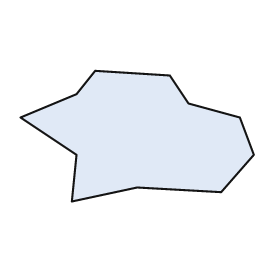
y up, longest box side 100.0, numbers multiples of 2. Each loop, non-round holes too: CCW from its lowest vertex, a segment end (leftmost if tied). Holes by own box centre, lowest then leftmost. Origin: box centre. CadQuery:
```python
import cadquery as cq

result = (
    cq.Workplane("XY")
    .moveTo(-28.0, -28.0)
    .lineTo(0.0, -22.0)
    .lineTo(36.0, -24.0)
    .lineTo(50.0, -8.0)
    .lineTo(44.0, 8.0)
    .lineTo(22.0, 14.0)
    .lineTo(14.0, 26.0)
    .lineTo(-18.0, 28.0)
    .lineTo(-26.0, 18.0)
    .lineTo(-50.0, 8.0)
    .lineTo(-26.0, -8.0)
    .close()
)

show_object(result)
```